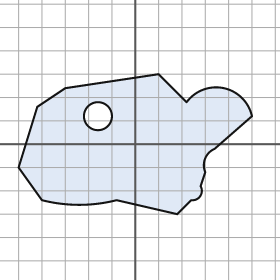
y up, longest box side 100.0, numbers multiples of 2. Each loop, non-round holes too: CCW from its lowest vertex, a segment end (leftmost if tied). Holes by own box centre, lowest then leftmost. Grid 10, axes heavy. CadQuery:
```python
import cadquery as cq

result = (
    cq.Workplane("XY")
    .moveTo(18.0, -30.0)
    .lineTo(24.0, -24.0)
    .threePointArc((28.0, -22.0), (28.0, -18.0))
    .lineTo(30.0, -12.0)
    .threePointArc((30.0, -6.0), (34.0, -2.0))
    .lineTo(50.0, 12.0)
    .threePointArc((38.0, 24.0), (22.0, 18.0))
    .lineTo(10.0, 30.0)
    .lineTo(-30.0, 24.0)
    .lineTo(-42.0, 16.0)
    .lineTo(-50.0, -10.0)
    .lineTo(-40.0, -24.0)
    .threePointArc((-24.0, -26.0), (-8.0, -24.0))
    .close()
    .moveTo(-16.0, 12.0)
    .circle(6.0)
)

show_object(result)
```